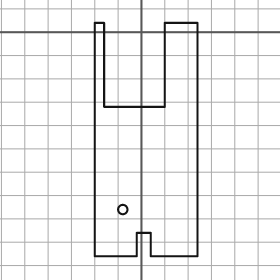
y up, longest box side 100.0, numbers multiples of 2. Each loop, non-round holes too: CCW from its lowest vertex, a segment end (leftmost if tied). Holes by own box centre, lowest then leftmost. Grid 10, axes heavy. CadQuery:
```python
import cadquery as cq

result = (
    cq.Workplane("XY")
    .moveTo(-20.0, -96.0)
    .lineTo(-2.0, -96.0)
    .lineTo(-2.0, -86.0)
    .lineTo(4.0, -86.0)
    .lineTo(4.0, -96.0)
    .lineTo(24.0, -96.0)
    .lineTo(24.0, 4.0)
    .lineTo(10.0, 4.0)
    .lineTo(10.0, -32.0)
    .lineTo(-16.0, -32.0)
    .lineTo(-16.0, 4.0)
    .lineTo(-20.0, 4.0)
    .close()
    .moveTo(-8.0, -76.0)
    .circle(2.0)
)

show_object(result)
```